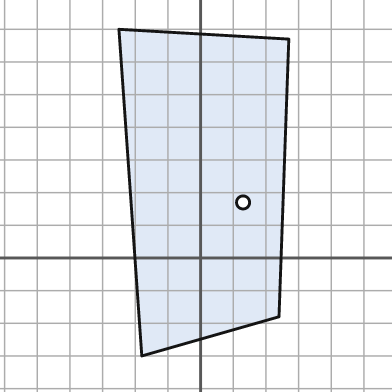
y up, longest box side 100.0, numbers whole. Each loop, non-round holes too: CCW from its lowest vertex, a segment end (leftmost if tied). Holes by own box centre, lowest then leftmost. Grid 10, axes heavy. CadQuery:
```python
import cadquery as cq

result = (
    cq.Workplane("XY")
    .moveTo(-18.0, -30.0)
    .lineTo(24.0, -18.0)
    .lineTo(27.0, 67.0)
    .lineTo(-25.0, 70.0)
    .close()
    .moveTo(13.0, 17.0)
    .circle(2.0)
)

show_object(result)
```